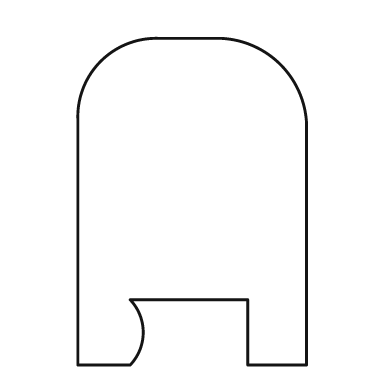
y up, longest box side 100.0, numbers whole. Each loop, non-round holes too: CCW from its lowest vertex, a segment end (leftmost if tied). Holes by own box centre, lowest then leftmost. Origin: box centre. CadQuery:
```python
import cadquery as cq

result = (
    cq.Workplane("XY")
    .moveTo(-35.0, -50.0)
    .lineTo(-19.0, -50.0)
    .threePointArc((-15.0, -40.0), (-19.0, -30.0))
    .lineTo(17.0, -30.0)
    .lineTo(17.0, -50.0)
    .lineTo(35.0, -50.0)
    .lineTo(35.0, 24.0)
    .threePointArc((27.0, 42.0), (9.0, 50.0))
    .lineTo(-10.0, 50.0)
    .threePointArc((-28.0, 43.0), (-35.0, 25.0))
    .close()
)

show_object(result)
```